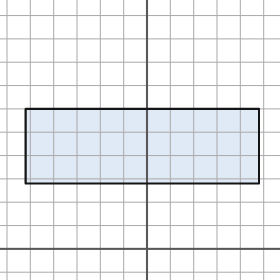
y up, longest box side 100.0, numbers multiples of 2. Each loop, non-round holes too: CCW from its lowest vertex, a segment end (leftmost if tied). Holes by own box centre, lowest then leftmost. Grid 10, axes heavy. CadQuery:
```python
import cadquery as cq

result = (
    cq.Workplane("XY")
    .moveTo(-52.0, 28.0)
    .lineTo(48.0, 28.0)
    .lineTo(48.0, 60.0)
    .lineTo(-52.0, 60.0)
    .close()
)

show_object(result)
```